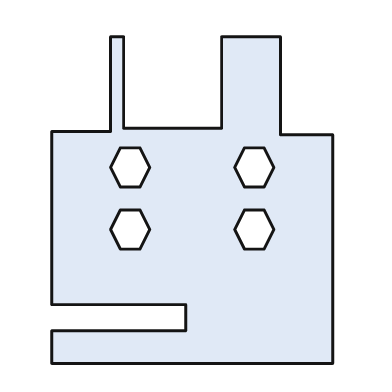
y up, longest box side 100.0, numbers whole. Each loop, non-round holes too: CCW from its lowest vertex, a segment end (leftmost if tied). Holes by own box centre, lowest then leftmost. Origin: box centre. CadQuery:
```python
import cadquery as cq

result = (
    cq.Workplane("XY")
    .moveTo(-43.0, -50.0)
    .lineTo(43.0, -50.0)
    .lineTo(43.0, 20.0)
    .lineTo(27.0, 20.0)
    .lineTo(27.0, 50.0)
    .lineTo(9.0, 50.0)
    .lineTo(9.0, 22.0)
    .lineTo(-21.0, 22.0)
    .lineTo(-21.0, 50.0)
    .lineTo(-25.0, 50.0)
    .lineTo(-25.0, 21.0)
    .lineTo(-43.0, 21.0)
    .lineTo(-43.0, -32.0)
    .lineTo(-2.0, -32.0)
    .lineTo(-2.0, -40.0)
    .lineTo(-43.0, -40.0)
    .close()
    .moveTo(-22.0, -15.0)
    .lineTo(-16.0, -15.0)
    .lineTo(-13.0, -9.0)
    .lineTo(-16.0, -3.0)
    .lineTo(-22.0, -3.0)
    .lineTo(-25.0, -9.0)
    .close()
    .moveTo(16.0, -15.0)
    .lineTo(22.0, -15.0)
    .lineTo(25.0, -9.0)
    .lineTo(22.0, -3.0)
    .lineTo(16.0, -3.0)
    .lineTo(13.0, -9.0)
    .close()
    .moveTo(-22.0, 4.0)
    .lineTo(-16.0, 4.0)
    .lineTo(-13.0, 10.0)
    .lineTo(-16.0, 16.0)
    .lineTo(-22.0, 16.0)
    .lineTo(-25.0, 10.0)
    .close()
    .moveTo(16.0, 4.0)
    .lineTo(22.0, 4.0)
    .lineTo(25.0, 10.0)
    .lineTo(22.0, 16.0)
    .lineTo(16.0, 16.0)
    .lineTo(13.0, 10.0)
    .close()
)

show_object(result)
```